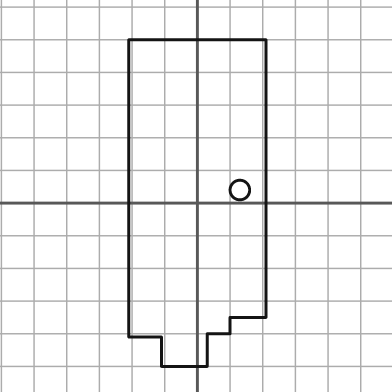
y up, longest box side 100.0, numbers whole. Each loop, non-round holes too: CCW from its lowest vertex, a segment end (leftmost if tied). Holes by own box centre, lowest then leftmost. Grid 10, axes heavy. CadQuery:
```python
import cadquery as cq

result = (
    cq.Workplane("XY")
    .moveTo(-11.0, -50.0)
    .lineTo(3.0, -50.0)
    .lineTo(3.0, -40.0)
    .lineTo(10.0, -40.0)
    .lineTo(10.0, -35.0)
    .lineTo(21.0, -35.0)
    .lineTo(21.0, 50.0)
    .lineTo(-21.0, 50.0)
    .lineTo(-21.0, -41.0)
    .lineTo(-11.0, -41.0)
    .close()
    .moveTo(13.0, 4.0)
    .circle(3.0)
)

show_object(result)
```